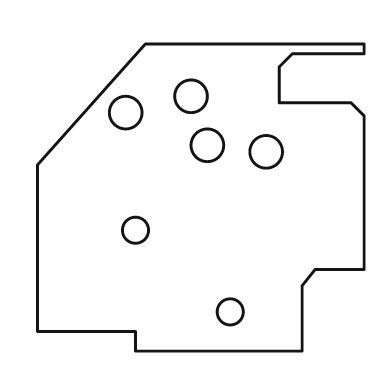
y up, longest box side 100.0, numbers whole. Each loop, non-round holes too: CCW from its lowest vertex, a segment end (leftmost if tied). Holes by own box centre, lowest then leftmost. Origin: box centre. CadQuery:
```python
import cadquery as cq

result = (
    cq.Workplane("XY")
    .moveTo(-20.0, -47.0)
    .lineTo(31.0, -47.0)
    .lineTo(31.0, -27.0)
    .lineTo(35.0, -22.0)
    .lineTo(50.0, -22.0)
    .lineTo(50.0, 25.0)
    .lineTo(46.0, 29.0)
    .lineTo(24.0, 29.0)
    .lineTo(24.0, 40.0)
    .lineTo(28.0, 44.0)
    .lineTo(50.0, 44.0)
    .lineTo(50.0, 47.0)
    .lineTo(-17.0, 47.0)
    .lineTo(-50.0, 10.0)
    .lineTo(-50.0, -41.0)
    .lineTo(-20.0, -41.0)
    .close()
    .moveTo(9.0, -35.0)
    .circle(4.0)
    .moveTo(-20.0, -10.0)
    .circle(4.0)
    .moveTo(20.0, 14.0)
    .circle(5.0)
    .moveTo(2.0, 16.0)
    .circle(5.0)
    .moveTo(-23.0, 26.0)
    .circle(5.0)
    .moveTo(-3.0, 31.0)
    .circle(5.0)
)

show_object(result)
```